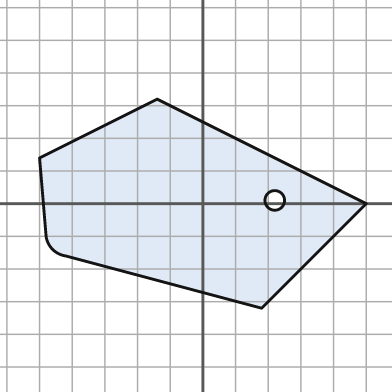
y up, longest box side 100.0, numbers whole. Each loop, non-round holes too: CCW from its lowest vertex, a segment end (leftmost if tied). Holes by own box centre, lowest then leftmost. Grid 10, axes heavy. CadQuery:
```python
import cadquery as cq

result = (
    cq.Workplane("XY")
    .moveTo(18.0, -32.0)
    .lineTo(50.0, 0.0)
    .lineTo(-14.0, 32.0)
    .lineTo(-50.0, 14.0)
    .lineTo(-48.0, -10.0)
    .threePointArc((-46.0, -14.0), (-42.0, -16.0))
    .close()
    .moveTo(22.0, 1.0)
    .circle(3.0)
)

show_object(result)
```